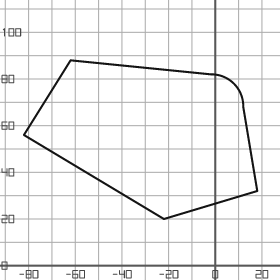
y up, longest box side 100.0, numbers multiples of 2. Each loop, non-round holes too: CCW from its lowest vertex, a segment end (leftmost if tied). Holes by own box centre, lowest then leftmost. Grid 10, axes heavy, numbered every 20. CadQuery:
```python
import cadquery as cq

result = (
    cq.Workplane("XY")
    .moveTo(-22.0, 20.0)
    .lineTo(18.0, 32.0)
    .lineTo(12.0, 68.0)
    .threePointArc((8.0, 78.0), (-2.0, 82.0))
    .lineTo(-62.0, 88.0)
    .lineTo(-82.0, 56.0)
    .close()
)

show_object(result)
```